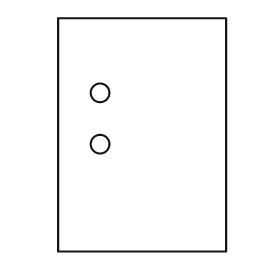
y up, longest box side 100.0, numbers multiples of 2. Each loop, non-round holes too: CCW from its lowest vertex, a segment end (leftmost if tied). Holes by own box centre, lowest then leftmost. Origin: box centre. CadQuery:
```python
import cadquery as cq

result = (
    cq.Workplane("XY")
    .moveTo(-36.0, -50.0)
    .lineTo(36.0, -50.0)
    .lineTo(36.0, 50.0)
    .lineTo(-36.0, 50.0)
    .close()
    .moveTo(-18.0, -4.0)
    .circle(4.0)
    .moveTo(-18.0, 18.0)
    .circle(4.0)
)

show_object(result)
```